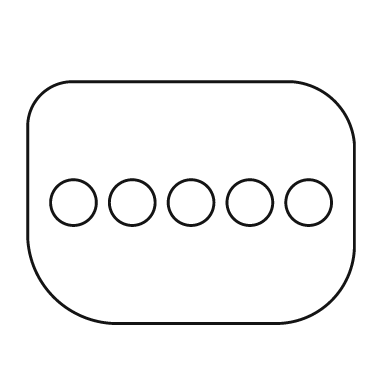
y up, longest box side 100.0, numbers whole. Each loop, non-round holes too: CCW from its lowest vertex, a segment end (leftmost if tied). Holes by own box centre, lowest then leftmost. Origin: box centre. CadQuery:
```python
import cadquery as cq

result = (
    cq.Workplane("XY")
    .moveTo(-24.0, -37.0)
    .lineTo(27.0, -37.0)
    .threePointArc((43.0, -30.0), (50.0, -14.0))
    .lineTo(50.0, 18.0)
    .threePointArc((44.0, 31.0), (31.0, 37.0))
    .lineTo(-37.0, 37.0)
    .threePointArc((-46.0, 33.0), (-50.0, 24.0))
    .lineTo(-50.0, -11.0)
    .threePointArc((-42.0, -29.0), (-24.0, -37.0))
    .close()
    .moveTo(-36.0, 0.0)
    .circle(7.0)
    .moveTo(-18.0, 0.0)
    .circle(7.0)
    .moveTo(0.0, 0.0)
    .circle(7.0)
    .moveTo(18.0, 0.0)
    .circle(7.0)
    .moveTo(36.0, 0.0)
    .circle(7.0)
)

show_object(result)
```